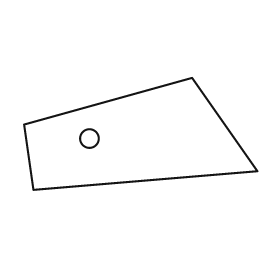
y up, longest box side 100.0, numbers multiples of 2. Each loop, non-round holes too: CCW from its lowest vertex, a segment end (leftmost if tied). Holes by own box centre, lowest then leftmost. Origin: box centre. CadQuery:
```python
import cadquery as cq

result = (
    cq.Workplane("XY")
    .moveTo(-46.0, -24.0)
    .lineTo(50.0, -16.0)
    .lineTo(22.0, 24.0)
    .lineTo(-50.0, 4.0)
    .close()
    .moveTo(-22.0, -2.0)
    .circle(4.0)
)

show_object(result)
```